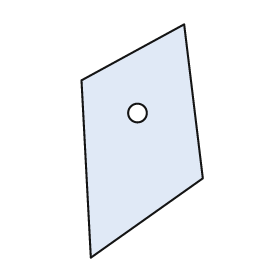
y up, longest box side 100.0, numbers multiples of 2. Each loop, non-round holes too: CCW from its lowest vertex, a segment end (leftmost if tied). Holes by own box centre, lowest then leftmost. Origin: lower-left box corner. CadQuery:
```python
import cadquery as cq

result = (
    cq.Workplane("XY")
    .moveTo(4.0, 0.0)
    .lineTo(52.0, 34.0)
    .lineTo(44.0, 100.0)
    .lineTo(0.0, 76.0)
    .close()
    .moveTo(24.0, 62.0)
    .circle(4.0)
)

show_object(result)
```